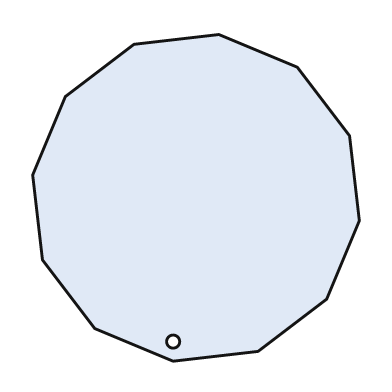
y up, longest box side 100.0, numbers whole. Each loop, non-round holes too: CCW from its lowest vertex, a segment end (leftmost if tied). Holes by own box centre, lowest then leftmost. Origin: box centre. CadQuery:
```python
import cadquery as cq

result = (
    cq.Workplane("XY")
    .moveTo(-7.0, -50.0)
    .lineTo(19.0, -47.0)
    .lineTo(40.0, -31.0)
    .lineTo(50.0, -7.0)
    .lineTo(47.0, 19.0)
    .lineTo(31.0, 40.0)
    .lineTo(7.0, 50.0)
    .lineTo(-19.0, 47.0)
    .lineTo(-40.0, 31.0)
    .lineTo(-50.0, 7.0)
    .lineTo(-47.0, -19.0)
    .lineTo(-31.0, -40.0)
    .close()
    .moveTo(-7.0, -44.0)
    .circle(2.0)
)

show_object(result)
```